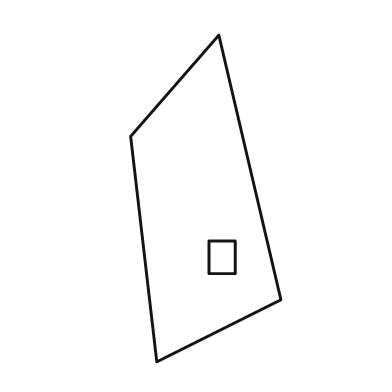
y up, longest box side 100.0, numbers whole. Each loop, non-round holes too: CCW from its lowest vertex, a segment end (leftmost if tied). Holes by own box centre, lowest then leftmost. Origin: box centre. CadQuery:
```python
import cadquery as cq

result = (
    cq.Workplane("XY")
    .moveTo(-15.0, -50.0)
    .lineTo(23.0, -31.0)
    .lineTo(4.0, 50.0)
    .lineTo(-23.0, 19.0)
    .close()
    .moveTo(1.0, -23.0)
    .lineTo(9.0, -23.0)
    .lineTo(9.0, -13.0)
    .lineTo(1.0, -13.0)
    .close()
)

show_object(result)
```